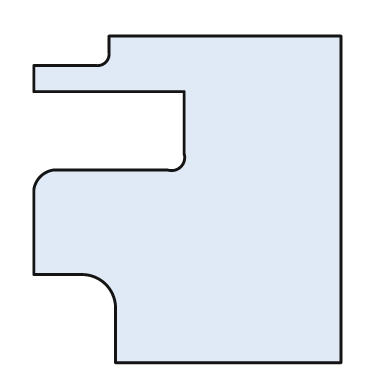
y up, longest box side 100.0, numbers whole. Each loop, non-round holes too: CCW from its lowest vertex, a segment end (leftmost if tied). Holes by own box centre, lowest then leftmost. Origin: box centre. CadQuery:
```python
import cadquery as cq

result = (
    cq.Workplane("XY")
    .moveTo(-22.0, -50.0)
    .lineTo(47.0, -50.0)
    .lineTo(47.0, 50.0)
    .lineTo(-24.0, 50.0)
    .lineTo(-24.0, 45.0)
    .threePointArc((-25.0, 42.0), (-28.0, 41.0))
    .lineTo(-47.0, 41.0)
    .lineTo(-47.0, 33.0)
    .lineTo(-1.0, 33.0)
    .lineTo(-1.0, 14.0)
    .threePointArc((-2.0, 10.0), (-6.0, 9.0))
    .lineTo(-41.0, 9.0)
    .threePointArc((-45.0, 7.0), (-47.0, 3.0))
    .lineTo(-47.0, -23.0)
    .lineTo(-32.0, -23.0)
    .threePointArc((-25.0, -26.0), (-22.0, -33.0))
    .close()
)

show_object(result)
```